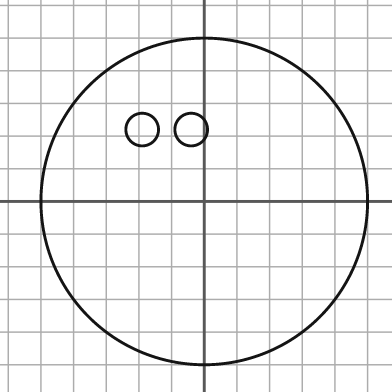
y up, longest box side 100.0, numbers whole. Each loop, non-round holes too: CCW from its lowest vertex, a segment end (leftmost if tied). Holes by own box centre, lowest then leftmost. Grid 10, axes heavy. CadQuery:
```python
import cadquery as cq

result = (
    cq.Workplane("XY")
    .moveTo(0.0, 0.0)
    .circle(50.0)
    .moveTo(-19.0, 22.0)
    .circle(5.0)
    .moveTo(-4.0, 22.0)
    .circle(5.0)
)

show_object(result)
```